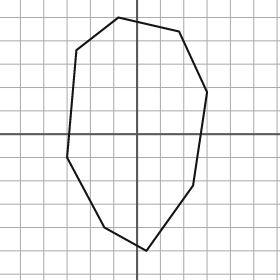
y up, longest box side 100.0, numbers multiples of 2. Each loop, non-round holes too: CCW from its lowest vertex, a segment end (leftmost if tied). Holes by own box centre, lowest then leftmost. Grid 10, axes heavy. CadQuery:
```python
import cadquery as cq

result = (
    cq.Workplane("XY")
    .moveTo(4.0, -50.0)
    .lineTo(24.0, -22.0)
    .lineTo(30.0, 18.0)
    .lineTo(18.0, 44.0)
    .lineTo(-8.0, 50.0)
    .lineTo(-26.0, 36.0)
    .lineTo(-30.0, -10.0)
    .lineTo(-14.0, -40.0)
    .close()
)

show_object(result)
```